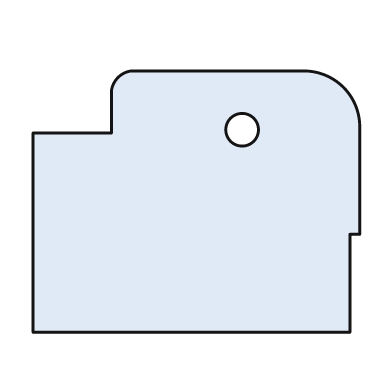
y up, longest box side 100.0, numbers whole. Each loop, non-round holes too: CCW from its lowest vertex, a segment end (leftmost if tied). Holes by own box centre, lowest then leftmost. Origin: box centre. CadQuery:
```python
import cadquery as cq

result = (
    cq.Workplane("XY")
    .moveTo(-50.0, -40.0)
    .lineTo(47.0, -40.0)
    .lineTo(47.0, -10.0)
    .lineTo(50.0, -10.0)
    .lineTo(50.0, 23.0)
    .threePointArc((45.0, 35.0), (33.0, 40.0))
    .lineTo(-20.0, 40.0)
    .threePointArc((-24.0, 38.0), (-26.0, 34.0))
    .lineTo(-26.0, 21.0)
    .lineTo(-50.0, 21.0)
    .close()
    .moveTo(14.0, 22.0)
    .circle(5.0)
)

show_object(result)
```